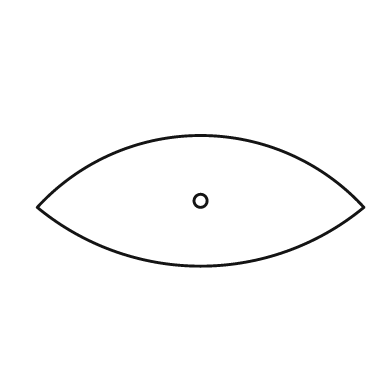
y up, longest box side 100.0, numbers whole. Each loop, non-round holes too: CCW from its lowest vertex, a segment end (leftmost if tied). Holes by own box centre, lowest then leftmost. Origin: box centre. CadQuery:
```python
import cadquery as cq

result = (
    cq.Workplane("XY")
    .moveTo(-50.0, -2.0)
    .threePointArc((0.0, -20.0), (50.0, -2.0))
    .threePointArc((0.0, 20.0), (-50.0, -2.0))
    .close()
    .moveTo(0.0, 0.0)
    .circle(2.0)
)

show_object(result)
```